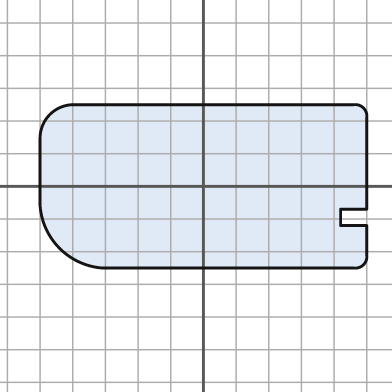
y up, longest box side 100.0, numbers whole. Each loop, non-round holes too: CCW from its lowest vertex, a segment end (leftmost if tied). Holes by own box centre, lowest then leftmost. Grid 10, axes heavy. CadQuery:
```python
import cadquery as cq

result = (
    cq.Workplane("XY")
    .moveTo(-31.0, -25.0)
    .lineTo(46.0, -25.0)
    .threePointArc((49.0, -24.0), (50.0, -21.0))
    .lineTo(50.0, -12.0)
    .lineTo(42.0, -12.0)
    .lineTo(42.0, -7.0)
    .lineTo(50.0, -7.0)
    .lineTo(50.0, 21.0)
    .threePointArc((49.0, 24.0), (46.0, 25.0))
    .lineTo(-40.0, 25.0)
    .threePointArc((-47.0, 22.0), (-50.0, 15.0))
    .lineTo(-50.0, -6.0)
    .threePointArc((-44.0, -19.0), (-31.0, -25.0))
    .close()
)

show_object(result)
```